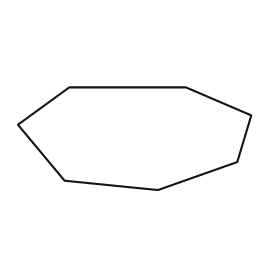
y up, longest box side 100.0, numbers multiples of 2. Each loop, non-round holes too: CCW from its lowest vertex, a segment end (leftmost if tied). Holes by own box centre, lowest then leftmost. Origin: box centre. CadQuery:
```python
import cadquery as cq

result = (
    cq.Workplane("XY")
    .moveTo(10.0, -22.0)
    .lineTo(44.0, -10.0)
    .lineTo(50.0, 10.0)
    .lineTo(22.0, 22.0)
    .lineTo(-28.0, 22.0)
    .lineTo(-50.0, 6.0)
    .lineTo(-30.0, -18.0)
    .close()
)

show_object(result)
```